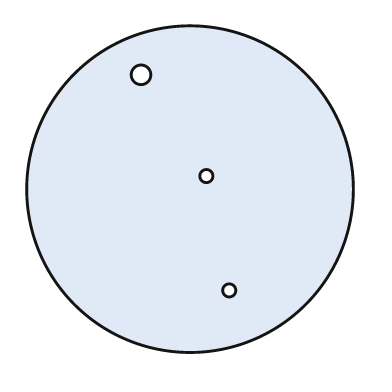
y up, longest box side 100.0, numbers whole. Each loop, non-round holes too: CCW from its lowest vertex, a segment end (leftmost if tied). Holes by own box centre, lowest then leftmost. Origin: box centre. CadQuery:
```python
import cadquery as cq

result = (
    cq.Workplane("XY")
    .moveTo(0.0, 0.0)
    .circle(50.0)
    .moveTo(12.0, -31.0)
    .circle(2.0)
    .moveTo(5.0, 4.0)
    .circle(2.0)
    .moveTo(-15.0, 35.0)
    .circle(3.0)
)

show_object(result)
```